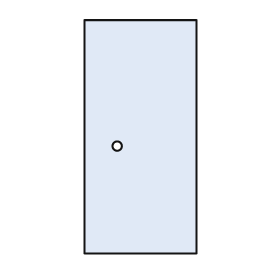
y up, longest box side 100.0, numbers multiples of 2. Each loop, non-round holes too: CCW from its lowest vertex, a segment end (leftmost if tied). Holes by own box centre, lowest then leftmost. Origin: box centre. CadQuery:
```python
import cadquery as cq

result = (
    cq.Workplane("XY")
    .moveTo(-24.0, -50.0)
    .lineTo(24.0, -50.0)
    .lineTo(24.0, 50.0)
    .lineTo(-24.0, 50.0)
    .close()
    .moveTo(-10.0, -4.0)
    .circle(2.0)
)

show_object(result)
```